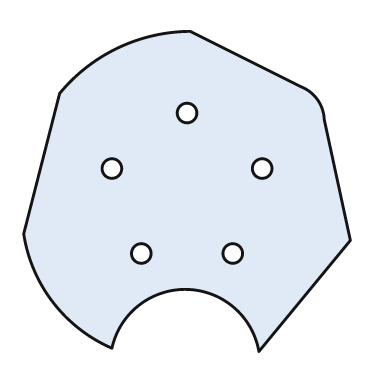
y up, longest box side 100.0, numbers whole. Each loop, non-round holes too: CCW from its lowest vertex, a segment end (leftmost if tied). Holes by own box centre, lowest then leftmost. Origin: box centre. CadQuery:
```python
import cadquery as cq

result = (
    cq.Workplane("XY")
    .moveTo(22.0, -49.0)
    .lineTo(50.0, -15.0)
    .lineTo(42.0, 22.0)
    .threePointArc((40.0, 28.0), (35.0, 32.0))
    .lineTo(1.0, 49.0)
    .threePointArc((-21.0, 44.0), (-39.0, 30.0))
    .lineTo(-50.0, -13.0)
    .threePointArc((-41.0, -34.0), (-23.0, -48.0))
    .threePointArc((0.0, -30.0), (22.0, -49.0))
    .close()
    .moveTo(-14.0, -19.0)
    .circle(3.0)
    .moveTo(14.0, -19.0)
    .circle(3.0)
    .moveTo(-23.0, 7.0)
    .circle(3.0)
    .moveTo(23.0, 7.0)
    .circle(3.0)
    .moveTo(0.0, 24.0)
    .circle(3.0)
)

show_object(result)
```